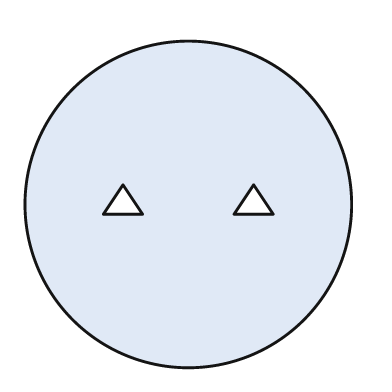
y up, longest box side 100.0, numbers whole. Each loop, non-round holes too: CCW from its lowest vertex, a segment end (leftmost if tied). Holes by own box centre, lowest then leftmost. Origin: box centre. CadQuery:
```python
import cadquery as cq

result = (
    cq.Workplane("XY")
    .moveTo(0.0, 0.0)
    .circle(50.0)
    .moveTo(-26.0, -3.0)
    .lineTo(-14.0, -3.0)
    .lineTo(-20.0, 6.0)
    .close()
    .moveTo(14.0, -3.0)
    .lineTo(26.0, -3.0)
    .lineTo(20.0, 6.0)
    .close()
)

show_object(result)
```